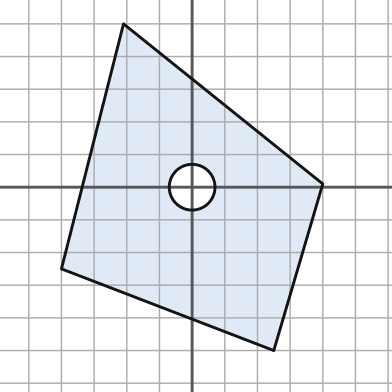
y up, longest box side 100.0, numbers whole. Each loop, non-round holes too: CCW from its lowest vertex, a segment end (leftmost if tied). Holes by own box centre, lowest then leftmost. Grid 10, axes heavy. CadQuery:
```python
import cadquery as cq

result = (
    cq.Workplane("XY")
    .moveTo(25.0, -50.0)
    .lineTo(40.0, 1.0)
    .lineTo(-21.0, 50.0)
    .lineTo(-40.0, -25.0)
    .close()
    .moveTo(0.0, 0.0)
    .circle(7.0)
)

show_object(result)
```